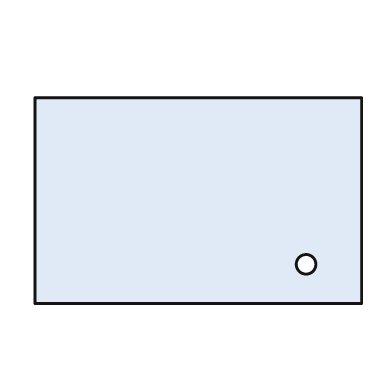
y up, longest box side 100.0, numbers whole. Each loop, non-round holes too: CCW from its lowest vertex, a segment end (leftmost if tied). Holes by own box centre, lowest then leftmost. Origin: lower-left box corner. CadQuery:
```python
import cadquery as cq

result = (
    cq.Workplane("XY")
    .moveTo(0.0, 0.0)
    .lineTo(100.0, 0.0)
    .lineTo(100.0, 63.0)
    .lineTo(0.0, 63.0)
    .close()
    .moveTo(83.0, 12.0)
    .circle(3.0)
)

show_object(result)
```